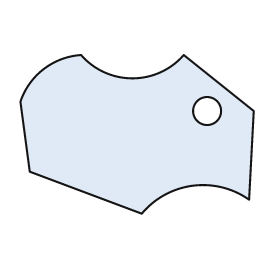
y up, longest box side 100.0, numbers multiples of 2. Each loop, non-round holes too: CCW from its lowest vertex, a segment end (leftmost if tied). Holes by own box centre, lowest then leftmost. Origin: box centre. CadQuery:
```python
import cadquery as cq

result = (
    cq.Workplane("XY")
    .moveTo(2.0, -34.0)
    .threePointArc((24.0, -22.0), (48.0, -28.0))
    .lineTo(50.0, 10.0)
    .lineTo(20.0, 34.0)
    .threePointArc((-2.0, 24.0), (-24.0, 34.0))
    .threePointArc((-40.0, 28.0), (-50.0, 14.0))
    .lineTo(-46.0, -16.0)
    .close()
    .moveTo(30.0, 10.0)
    .circle(6.0)
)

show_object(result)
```